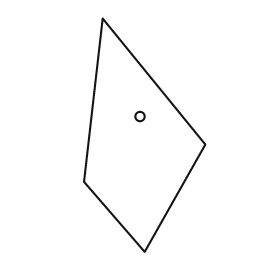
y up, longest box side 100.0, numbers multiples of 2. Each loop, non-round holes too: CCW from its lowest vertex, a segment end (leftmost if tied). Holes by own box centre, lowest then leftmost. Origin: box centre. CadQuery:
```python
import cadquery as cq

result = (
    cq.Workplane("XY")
    .moveTo(0.0, -50.0)
    .lineTo(26.0, -4.0)
    .lineTo(-18.0, 50.0)
    .lineTo(-26.0, -20.0)
    .close()
    .moveTo(-2.0, 8.0)
    .circle(2.0)
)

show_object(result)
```